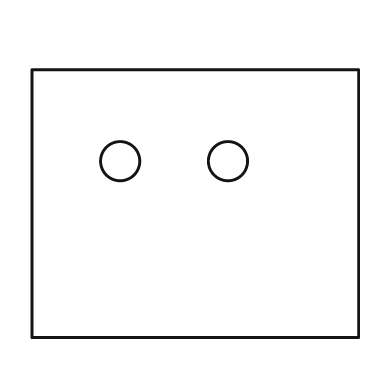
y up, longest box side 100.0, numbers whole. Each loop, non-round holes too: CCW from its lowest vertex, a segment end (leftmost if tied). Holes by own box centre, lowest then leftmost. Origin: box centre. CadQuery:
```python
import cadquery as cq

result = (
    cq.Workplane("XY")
    .moveTo(-50.0, -41.0)
    .lineTo(50.0, -41.0)
    .lineTo(50.0, 41.0)
    .lineTo(-50.0, 41.0)
    .close()
    .moveTo(-23.0, 13.0)
    .circle(6.0)
    .moveTo(10.0, 13.0)
    .circle(6.0)
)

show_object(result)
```